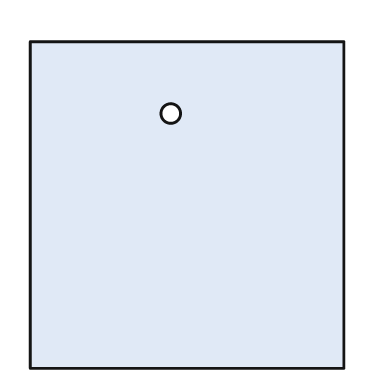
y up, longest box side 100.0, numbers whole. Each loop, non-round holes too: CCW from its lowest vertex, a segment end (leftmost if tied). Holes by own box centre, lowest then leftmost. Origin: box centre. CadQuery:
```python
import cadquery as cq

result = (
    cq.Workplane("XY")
    .moveTo(-48.0, -50.0)
    .lineTo(48.0, -50.0)
    .lineTo(48.0, 50.0)
    .lineTo(-48.0, 50.0)
    .close()
    .moveTo(-5.0, 28.0)
    .circle(3.0)
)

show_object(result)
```